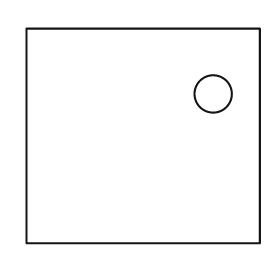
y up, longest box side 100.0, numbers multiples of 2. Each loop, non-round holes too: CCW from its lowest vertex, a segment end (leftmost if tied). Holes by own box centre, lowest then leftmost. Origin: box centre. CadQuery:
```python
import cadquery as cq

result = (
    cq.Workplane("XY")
    .moveTo(-50.0, -46.0)
    .lineTo(50.0, -46.0)
    .lineTo(50.0, 46.0)
    .lineTo(-50.0, 46.0)
    .close()
    .moveTo(30.0, 18.0)
    .circle(8.0)
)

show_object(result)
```